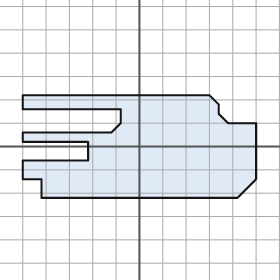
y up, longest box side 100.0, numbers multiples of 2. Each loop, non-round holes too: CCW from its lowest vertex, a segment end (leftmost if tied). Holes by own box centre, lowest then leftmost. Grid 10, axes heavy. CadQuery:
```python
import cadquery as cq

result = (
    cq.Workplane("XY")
    .moveTo(-42.0, -22.0)
    .lineTo(42.0, -22.0)
    .lineTo(50.0, -14.0)
    .lineTo(50.0, 10.0)
    .lineTo(38.0, 10.0)
    .lineTo(34.0, 14.0)
    .lineTo(34.0, 18.0)
    .lineTo(30.0, 22.0)
    .lineTo(-50.0, 22.0)
    .lineTo(-50.0, 16.0)
    .lineTo(-8.0, 16.0)
    .lineTo(-8.0, 10.0)
    .lineTo(-12.0, 6.0)
    .lineTo(-50.0, 6.0)
    .lineTo(-50.0, 2.0)
    .lineTo(-22.0, 2.0)
    .lineTo(-22.0, -6.0)
    .lineTo(-50.0, -6.0)
    .lineTo(-50.0, -14.0)
    .lineTo(-42.0, -14.0)
    .close()
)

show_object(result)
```